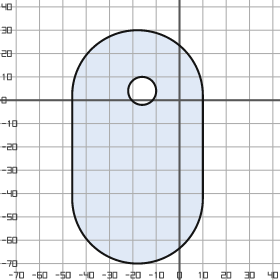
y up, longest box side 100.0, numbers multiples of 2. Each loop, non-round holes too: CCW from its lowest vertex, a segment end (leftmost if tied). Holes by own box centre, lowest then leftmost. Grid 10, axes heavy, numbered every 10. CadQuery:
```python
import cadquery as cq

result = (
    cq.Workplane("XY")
    .moveTo(-46.0, -42.0)
    .threePointArc((-18.0, -70.0), (10.0, -42.0))
    .lineTo(10.0, 2.0)
    .threePointArc((-18.0, 30.0), (-46.0, 2.0))
    .close()
    .moveTo(-16.0, 4.0)
    .circle(6.0)
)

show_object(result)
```